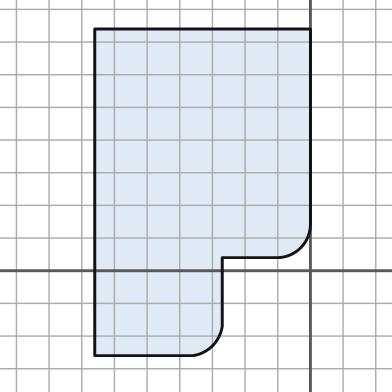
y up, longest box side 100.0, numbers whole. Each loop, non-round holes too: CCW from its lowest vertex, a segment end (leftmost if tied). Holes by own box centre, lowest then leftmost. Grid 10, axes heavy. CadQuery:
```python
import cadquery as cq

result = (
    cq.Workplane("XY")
    .moveTo(-66.0, -26.0)
    .lineTo(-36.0, -26.0)
    .threePointArc((-30.0, -23.0), (-27.0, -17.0))
    .lineTo(-27.0, 4.0)
    .lineTo(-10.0, 4.0)
    .threePointArc((-3.0, 7.0), (0.0, 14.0))
    .lineTo(0.0, 74.0)
    .lineTo(-66.0, 74.0)
    .close()
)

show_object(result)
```